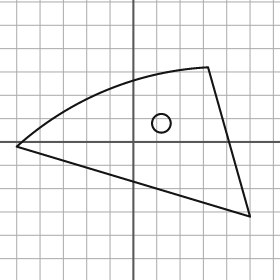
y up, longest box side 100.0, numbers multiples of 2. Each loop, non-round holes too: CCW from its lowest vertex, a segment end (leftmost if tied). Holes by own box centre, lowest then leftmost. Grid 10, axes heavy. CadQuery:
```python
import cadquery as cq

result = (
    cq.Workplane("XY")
    .moveTo(50.0, -32.0)
    .lineTo(32.0, 32.0)
    .threePointArc((-12.0, 22.0), (-50.0, -2.0))
    .close()
    .moveTo(12.0, 8.0)
    .circle(4.0)
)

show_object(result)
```